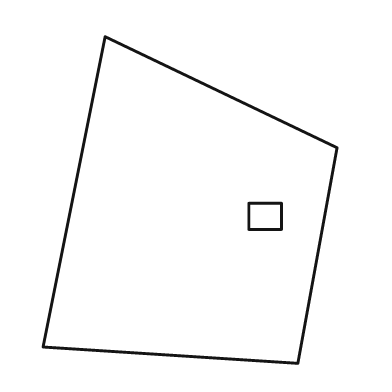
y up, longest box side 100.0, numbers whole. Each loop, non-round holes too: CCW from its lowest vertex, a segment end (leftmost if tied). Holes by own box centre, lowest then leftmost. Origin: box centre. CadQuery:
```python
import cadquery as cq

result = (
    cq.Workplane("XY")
    .moveTo(33.0, -50.0)
    .lineTo(45.0, 16.0)
    .lineTo(-26.0, 50.0)
    .lineTo(-45.0, -45.0)
    .close()
    .moveTo(18.0, -9.0)
    .lineTo(28.0, -9.0)
    .lineTo(28.0, -1.0)
    .lineTo(18.0, -1.0)
    .close()
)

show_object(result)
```